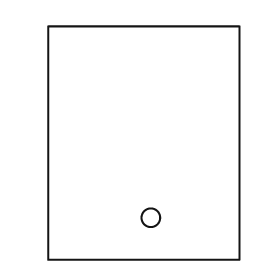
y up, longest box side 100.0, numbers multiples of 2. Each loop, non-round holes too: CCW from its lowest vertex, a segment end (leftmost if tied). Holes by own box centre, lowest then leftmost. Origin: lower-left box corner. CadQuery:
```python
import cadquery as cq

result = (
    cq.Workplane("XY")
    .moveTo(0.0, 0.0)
    .lineTo(82.0, 0.0)
    .lineTo(82.0, 100.0)
    .lineTo(0.0, 100.0)
    .close()
    .moveTo(44.0, 18.0)
    .circle(4.0)
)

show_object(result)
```